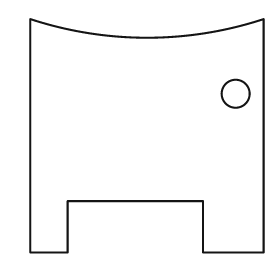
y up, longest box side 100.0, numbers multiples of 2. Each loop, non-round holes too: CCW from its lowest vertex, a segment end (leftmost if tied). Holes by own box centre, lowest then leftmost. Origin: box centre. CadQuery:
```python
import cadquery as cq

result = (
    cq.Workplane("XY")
    .moveTo(-50.0, -50.0)
    .lineTo(-34.0, -50.0)
    .lineTo(-34.0, -28.0)
    .lineTo(24.0, -28.0)
    .lineTo(24.0, -50.0)
    .lineTo(50.0, -50.0)
    .lineTo(50.0, 50.0)
    .threePointArc((0.0, 42.0), (-50.0, 50.0))
    .close()
    .moveTo(38.0, 18.0)
    .circle(6.0)
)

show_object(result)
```